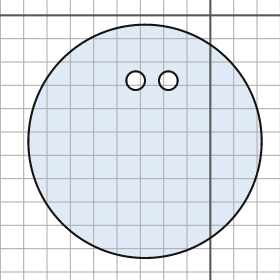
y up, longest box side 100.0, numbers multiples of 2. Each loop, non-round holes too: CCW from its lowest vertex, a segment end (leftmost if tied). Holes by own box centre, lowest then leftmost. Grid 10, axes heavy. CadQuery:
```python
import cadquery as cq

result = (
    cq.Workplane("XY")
    .moveTo(-28.0, -54.0)
    .circle(50.0)
    .moveTo(-32.0, -28.0)
    .circle(4.0)
    .moveTo(-18.0, -28.0)
    .circle(4.0)
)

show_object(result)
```